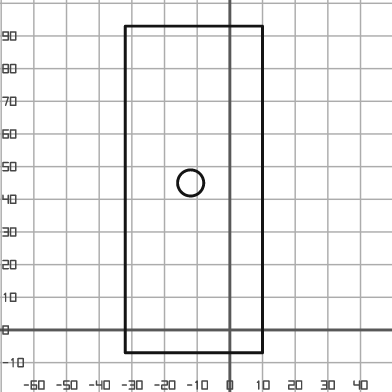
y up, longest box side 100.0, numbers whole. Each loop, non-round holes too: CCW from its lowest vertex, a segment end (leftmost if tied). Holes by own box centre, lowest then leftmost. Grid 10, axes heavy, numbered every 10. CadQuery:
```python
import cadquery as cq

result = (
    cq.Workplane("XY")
    .moveTo(-32.0, -7.0)
    .lineTo(10.0, -7.0)
    .lineTo(10.0, 93.0)
    .lineTo(-32.0, 93.0)
    .close()
    .moveTo(-12.0, 45.0)
    .circle(4.0)
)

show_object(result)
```